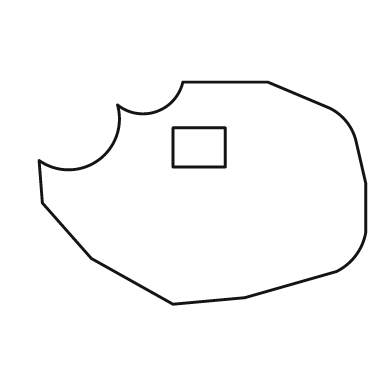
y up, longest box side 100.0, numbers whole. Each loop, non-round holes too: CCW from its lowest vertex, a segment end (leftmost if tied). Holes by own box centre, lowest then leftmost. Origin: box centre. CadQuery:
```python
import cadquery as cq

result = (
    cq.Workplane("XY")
    .moveTo(-9.0, -34.0)
    .lineTo(13.0, -32.0)
    .lineTo(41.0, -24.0)
    .threePointArc((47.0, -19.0), (50.0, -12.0))
    .lineTo(50.0, 3.0)
    .lineTo(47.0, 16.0)
    .threePointArc((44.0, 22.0), (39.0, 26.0))
    .lineTo(20.0, 34.0)
    .lineTo(-6.0, 34.0)
    .threePointArc((-14.0, 25.0), (-26.0, 27.0))
    .threePointArc((-32.0, 10.0), (-50.0, 10.0))
    .lineTo(-49.0, -3.0)
    .lineTo(-34.0, -20.0)
    .close()
    .moveTo(-9.0, 8.0)
    .lineTo(7.0, 8.0)
    .lineTo(7.0, 20.0)
    .lineTo(-9.0, 20.0)
    .close()
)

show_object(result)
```